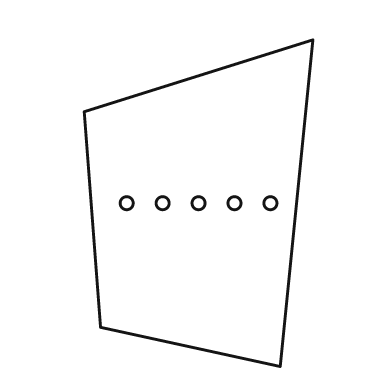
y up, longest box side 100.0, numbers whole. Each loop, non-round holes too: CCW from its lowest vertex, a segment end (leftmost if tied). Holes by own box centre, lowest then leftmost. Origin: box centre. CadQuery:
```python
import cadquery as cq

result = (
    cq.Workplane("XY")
    .moveTo(25.0, -50.0)
    .lineTo(35.0, 50.0)
    .lineTo(-35.0, 28.0)
    .lineTo(-30.0, -38.0)
    .close()
    .moveTo(-22.0, 0.0)
    .circle(2.0)
    .moveTo(-11.0, 0.0)
    .circle(2.0)
    .moveTo(0.0, 0.0)
    .circle(2.0)
    .moveTo(11.0, 0.0)
    .circle(2.0)
    .moveTo(22.0, 0.0)
    .circle(2.0)
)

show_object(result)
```